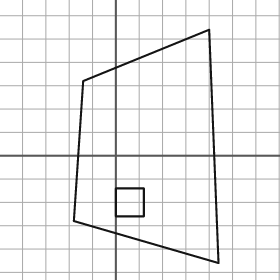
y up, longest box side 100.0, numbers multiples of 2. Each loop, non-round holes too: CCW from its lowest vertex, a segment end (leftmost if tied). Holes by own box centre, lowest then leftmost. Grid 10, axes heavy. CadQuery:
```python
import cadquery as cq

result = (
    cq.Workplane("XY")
    .moveTo(44.0, -46.0)
    .lineTo(40.0, 54.0)
    .lineTo(-14.0, 32.0)
    .lineTo(-18.0, -28.0)
    .close()
    .moveTo(0.0, -26.0)
    .lineTo(12.0, -26.0)
    .lineTo(12.0, -14.0)
    .lineTo(0.0, -14.0)
    .close()
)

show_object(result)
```